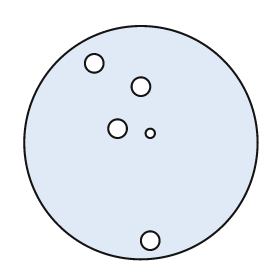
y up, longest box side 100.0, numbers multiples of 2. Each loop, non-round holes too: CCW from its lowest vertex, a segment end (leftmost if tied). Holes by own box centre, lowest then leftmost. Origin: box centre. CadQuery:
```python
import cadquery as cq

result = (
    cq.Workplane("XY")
    .moveTo(0.0, 0.0)
    .circle(50.0)
    .moveTo(4.0, -42.0)
    .circle(4.0)
    .moveTo(4.0, 4.0)
    .circle(2.0)
    .moveTo(-10.0, 6.0)
    .circle(4.0)
    .moveTo(0.0, 24.0)
    .circle(4.0)
    .moveTo(-20.0, 34.0)
    .circle(4.0)
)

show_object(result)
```